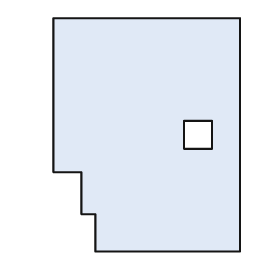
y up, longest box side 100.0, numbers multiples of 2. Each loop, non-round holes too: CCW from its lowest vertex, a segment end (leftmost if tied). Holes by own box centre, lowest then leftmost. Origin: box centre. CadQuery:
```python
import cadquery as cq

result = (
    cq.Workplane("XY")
    .moveTo(-22.0, -50.0)
    .lineTo(40.0, -50.0)
    .lineTo(40.0, 50.0)
    .lineTo(-40.0, 50.0)
    .lineTo(-40.0, -16.0)
    .lineTo(-28.0, -16.0)
    .lineTo(-28.0, -34.0)
    .lineTo(-22.0, -34.0)
    .close()
    .moveTo(16.0, -6.0)
    .lineTo(28.0, -6.0)
    .lineTo(28.0, 6.0)
    .lineTo(16.0, 6.0)
    .close()
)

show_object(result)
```